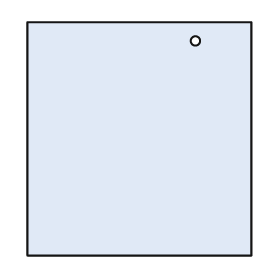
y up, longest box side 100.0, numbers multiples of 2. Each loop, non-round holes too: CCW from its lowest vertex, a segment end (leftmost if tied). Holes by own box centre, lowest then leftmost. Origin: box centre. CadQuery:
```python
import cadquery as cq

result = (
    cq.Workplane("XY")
    .moveTo(-48.0, -50.0)
    .lineTo(48.0, -50.0)
    .lineTo(48.0, 50.0)
    .lineTo(-48.0, 50.0)
    .close()
    .moveTo(24.0, 42.0)
    .circle(2.0)
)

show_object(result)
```